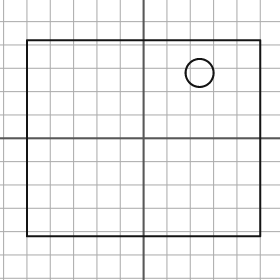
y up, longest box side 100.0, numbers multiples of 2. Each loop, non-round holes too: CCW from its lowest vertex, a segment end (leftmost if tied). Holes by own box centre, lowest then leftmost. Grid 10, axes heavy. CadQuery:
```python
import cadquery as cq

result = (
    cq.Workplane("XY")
    .moveTo(-50.0, -42.0)
    .lineTo(50.0, -42.0)
    .lineTo(50.0, 42.0)
    .lineTo(-50.0, 42.0)
    .close()
    .moveTo(24.0, 28.0)
    .circle(6.0)
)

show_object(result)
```